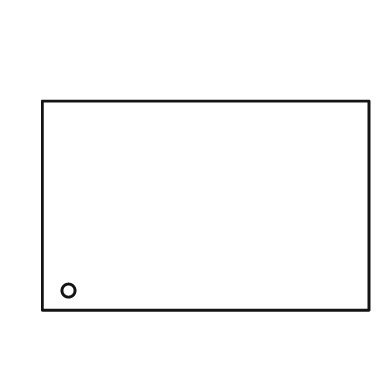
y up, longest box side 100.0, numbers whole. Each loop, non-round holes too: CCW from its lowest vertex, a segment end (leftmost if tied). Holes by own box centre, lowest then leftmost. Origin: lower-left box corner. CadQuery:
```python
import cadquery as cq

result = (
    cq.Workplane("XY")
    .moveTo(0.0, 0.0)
    .lineTo(100.0, 0.0)
    .lineTo(100.0, 64.0)
    .lineTo(0.0, 64.0)
    .close()
    .moveTo(8.0, 6.0)
    .circle(2.0)
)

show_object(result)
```